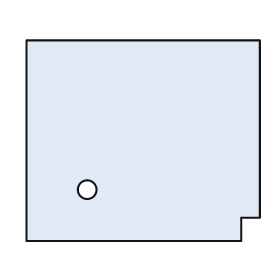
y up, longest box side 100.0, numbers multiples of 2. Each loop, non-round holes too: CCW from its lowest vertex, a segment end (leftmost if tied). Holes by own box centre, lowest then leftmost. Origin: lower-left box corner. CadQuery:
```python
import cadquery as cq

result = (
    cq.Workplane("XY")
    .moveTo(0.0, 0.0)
    .lineTo(92.0, 0.0)
    .lineTo(92.0, 10.0)
    .lineTo(100.0, 10.0)
    .lineTo(100.0, 86.0)
    .lineTo(0.0, 86.0)
    .close()
    .moveTo(26.0, 22.0)
    .circle(4.0)
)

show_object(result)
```